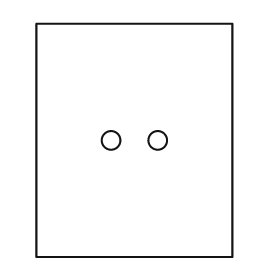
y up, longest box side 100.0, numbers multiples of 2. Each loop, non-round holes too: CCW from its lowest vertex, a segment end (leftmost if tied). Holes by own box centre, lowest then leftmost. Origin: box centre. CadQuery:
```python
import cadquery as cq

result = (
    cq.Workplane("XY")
    .moveTo(-42.0, -50.0)
    .lineTo(42.0, -50.0)
    .lineTo(42.0, 50.0)
    .lineTo(-42.0, 50.0)
    .close()
    .moveTo(-10.0, 0.0)
    .circle(4.0)
    .moveTo(10.0, 0.0)
    .circle(4.0)
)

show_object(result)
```